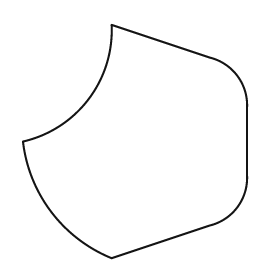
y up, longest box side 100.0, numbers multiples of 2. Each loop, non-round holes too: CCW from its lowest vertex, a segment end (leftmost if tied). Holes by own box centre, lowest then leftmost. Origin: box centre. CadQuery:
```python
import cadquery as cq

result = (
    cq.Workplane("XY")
    .moveTo(-10.0, -50.0)
    .lineTo(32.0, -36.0)
    .threePointArc((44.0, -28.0), (48.0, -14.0))
    .lineTo(48.0, 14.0)
    .threePointArc((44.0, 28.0), (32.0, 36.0))
    .lineTo(-10.0, 50.0)
    .threePointArc((-20.0, 18.0), (-48.0, 0.0))
    .threePointArc((-36.0, -30.0), (-10.0, -50.0))
    .close()
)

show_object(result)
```